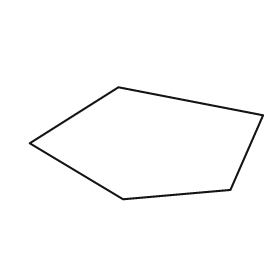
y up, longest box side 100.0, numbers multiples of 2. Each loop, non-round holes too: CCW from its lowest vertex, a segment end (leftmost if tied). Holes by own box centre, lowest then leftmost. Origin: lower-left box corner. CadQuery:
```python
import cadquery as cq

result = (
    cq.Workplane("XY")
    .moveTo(40.0, 0.0)
    .lineTo(86.0, 4.0)
    .lineTo(100.0, 36.0)
    .lineTo(38.0, 48.0)
    .lineTo(0.0, 24.0)
    .close()
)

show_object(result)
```